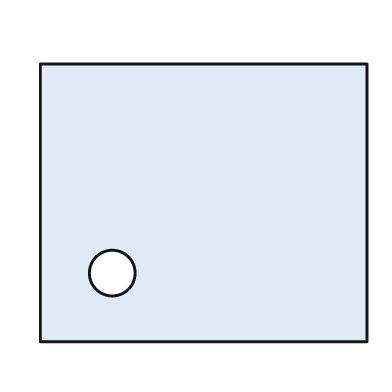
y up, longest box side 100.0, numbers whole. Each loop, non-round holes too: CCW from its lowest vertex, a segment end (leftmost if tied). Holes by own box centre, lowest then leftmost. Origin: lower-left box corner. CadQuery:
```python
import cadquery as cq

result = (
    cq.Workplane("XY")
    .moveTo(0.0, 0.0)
    .lineTo(100.0, 0.0)
    .lineTo(100.0, 85.0)
    .lineTo(0.0, 85.0)
    .close()
    .moveTo(22.0, 21.0)
    .circle(7.0)
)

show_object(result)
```